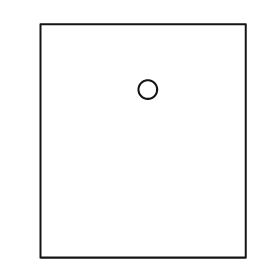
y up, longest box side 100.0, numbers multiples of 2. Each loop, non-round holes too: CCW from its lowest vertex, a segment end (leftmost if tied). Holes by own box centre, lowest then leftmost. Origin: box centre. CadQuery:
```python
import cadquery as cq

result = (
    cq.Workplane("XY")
    .moveTo(-44.0, -50.0)
    .lineTo(44.0, -50.0)
    .lineTo(44.0, 50.0)
    .lineTo(-44.0, 50.0)
    .close()
    .moveTo(2.0, 22.0)
    .circle(4.0)
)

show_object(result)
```